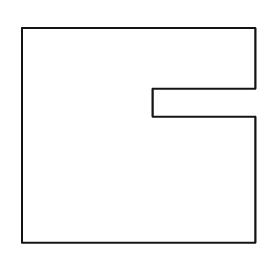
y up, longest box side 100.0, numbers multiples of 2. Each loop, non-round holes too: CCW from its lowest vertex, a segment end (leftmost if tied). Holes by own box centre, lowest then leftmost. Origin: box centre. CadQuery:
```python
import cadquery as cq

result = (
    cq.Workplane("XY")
    .moveTo(-50.0, -46.0)
    .lineTo(50.0, -46.0)
    .lineTo(50.0, 8.0)
    .lineTo(6.0, 8.0)
    .lineTo(6.0, 20.0)
    .lineTo(50.0, 20.0)
    .lineTo(50.0, 46.0)
    .lineTo(-50.0, 46.0)
    .close()
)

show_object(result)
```